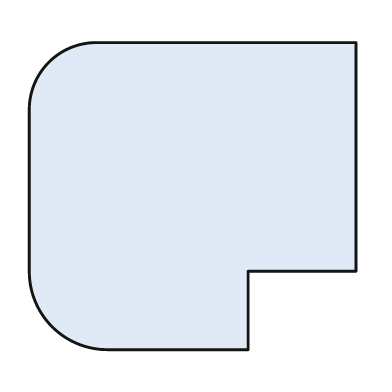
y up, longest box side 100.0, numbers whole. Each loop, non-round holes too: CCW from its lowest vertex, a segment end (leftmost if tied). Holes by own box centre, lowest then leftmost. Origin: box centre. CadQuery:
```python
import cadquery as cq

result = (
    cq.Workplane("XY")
    .moveTo(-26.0, -47.0)
    .lineTo(17.0, -47.0)
    .lineTo(17.0, -23.0)
    .lineTo(50.0, -23.0)
    .lineTo(50.0, 47.0)
    .lineTo(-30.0, 47.0)
    .threePointArc((-44.0, 41.0), (-50.0, 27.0))
    .lineTo(-50.0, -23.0)
    .threePointArc((-43.0, -40.0), (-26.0, -47.0))
    .close()
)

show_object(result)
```